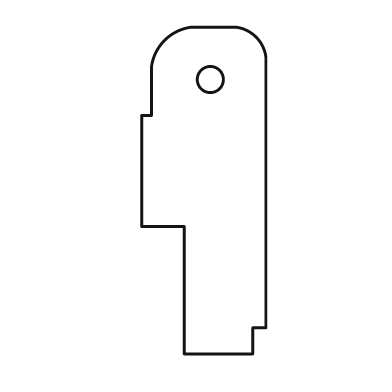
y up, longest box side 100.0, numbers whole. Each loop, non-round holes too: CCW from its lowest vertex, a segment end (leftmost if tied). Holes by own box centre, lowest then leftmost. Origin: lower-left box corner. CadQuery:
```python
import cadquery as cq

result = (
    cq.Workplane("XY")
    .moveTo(13.0, 0.0)
    .lineTo(34.0, 0.0)
    .lineTo(34.0, 8.0)
    .lineTo(38.0, 8.0)
    .lineTo(38.0, 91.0)
    .threePointArc((35.0, 97.0), (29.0, 100.0))
    .lineTo(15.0, 100.0)
    .threePointArc((7.0, 96.0), (3.0, 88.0))
    .lineTo(3.0, 73.0)
    .lineTo(0.0, 73.0)
    .lineTo(0.0, 39.0)
    .lineTo(13.0, 39.0)
    .close()
    .moveTo(21.0, 84.0)
    .circle(4.0)
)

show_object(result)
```